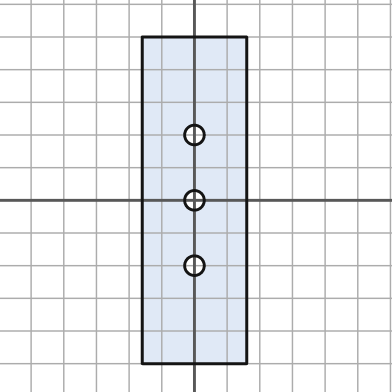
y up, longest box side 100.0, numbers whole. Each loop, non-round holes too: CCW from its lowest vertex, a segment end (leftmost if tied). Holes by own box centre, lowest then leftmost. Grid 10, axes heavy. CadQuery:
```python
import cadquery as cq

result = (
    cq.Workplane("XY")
    .moveTo(-16.0, -50.0)
    .lineTo(16.0, -50.0)
    .lineTo(16.0, 50.0)
    .lineTo(-16.0, 50.0)
    .close()
    .moveTo(0.0, -20.0)
    .circle(3.0)
    .moveTo(0.0, 0.0)
    .circle(3.0)
    .moveTo(0.0, 20.0)
    .circle(3.0)
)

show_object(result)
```